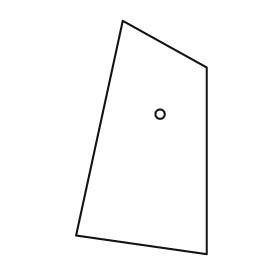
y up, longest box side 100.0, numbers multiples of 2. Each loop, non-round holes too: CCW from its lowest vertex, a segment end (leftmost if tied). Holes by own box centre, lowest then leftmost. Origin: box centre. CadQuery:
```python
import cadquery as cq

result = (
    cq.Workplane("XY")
    .moveTo(28.0, -50.0)
    .lineTo(28.0, 30.0)
    .lineTo(-8.0, 50.0)
    .lineTo(-28.0, -42.0)
    .close()
    .moveTo(8.0, 10.0)
    .circle(2.0)
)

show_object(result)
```